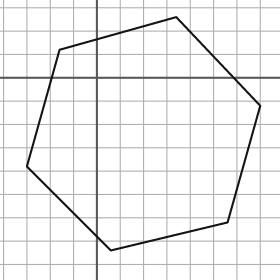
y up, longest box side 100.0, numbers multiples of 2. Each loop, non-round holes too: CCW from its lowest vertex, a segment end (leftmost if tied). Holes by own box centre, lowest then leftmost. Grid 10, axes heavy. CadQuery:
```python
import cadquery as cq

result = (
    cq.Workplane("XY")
    .moveTo(6.0, -74.0)
    .lineTo(56.0, -62.0)
    .lineTo(70.0, -12.0)
    .lineTo(34.0, 26.0)
    .lineTo(-16.0, 12.0)
    .lineTo(-30.0, -38.0)
    .close()
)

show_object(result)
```